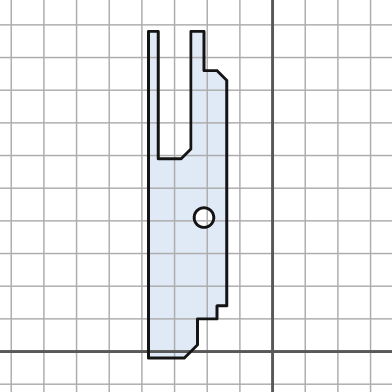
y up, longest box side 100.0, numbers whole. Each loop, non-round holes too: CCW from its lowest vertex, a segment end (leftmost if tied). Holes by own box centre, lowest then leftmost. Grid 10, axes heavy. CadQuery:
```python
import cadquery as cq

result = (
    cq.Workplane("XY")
    .moveTo(-38.0, -2.0)
    .lineTo(-27.0, -2.0)
    .lineTo(-23.0, 2.0)
    .lineTo(-23.0, 10.0)
    .lineTo(-17.0, 10.0)
    .lineTo(-17.0, 14.0)
    .lineTo(-14.0, 14.0)
    .lineTo(-14.0, 83.0)
    .lineTo(-17.0, 86.0)
    .lineTo(-21.0, 86.0)
    .lineTo(-21.0, 98.0)
    .lineTo(-25.0, 98.0)
    .lineTo(-25.0, 62.0)
    .lineTo(-28.0, 59.0)
    .lineTo(-35.0, 59.0)
    .lineTo(-35.0, 98.0)
    .lineTo(-38.0, 98.0)
    .close()
    .moveTo(-21.0, 41.0)
    .circle(3.0)
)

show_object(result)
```